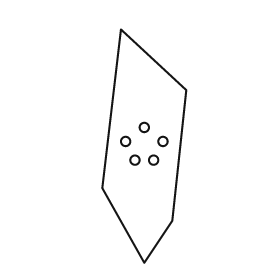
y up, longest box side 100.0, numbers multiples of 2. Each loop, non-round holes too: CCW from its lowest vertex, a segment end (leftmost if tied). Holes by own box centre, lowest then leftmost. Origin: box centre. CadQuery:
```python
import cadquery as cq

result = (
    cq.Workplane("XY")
    .moveTo(0.0, -50.0)
    .lineTo(12.0, -32.0)
    .lineTo(18.0, 24.0)
    .lineTo(-10.0, 50.0)
    .lineTo(-18.0, -18.0)
    .close()
    .moveTo(-4.0, -6.0)
    .circle(2.0)
    .moveTo(4.0, -6.0)
    .circle(2.0)
    .moveTo(-8.0, 2.0)
    .circle(2.0)
    .moveTo(8.0, 2.0)
    .circle(2.0)
    .moveTo(0.0, 8.0)
    .circle(2.0)
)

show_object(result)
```